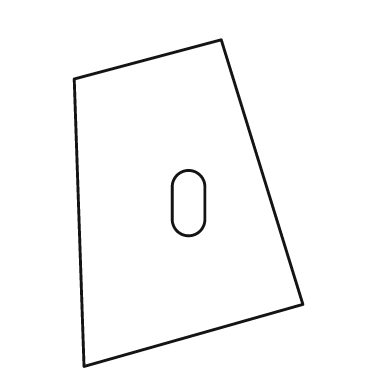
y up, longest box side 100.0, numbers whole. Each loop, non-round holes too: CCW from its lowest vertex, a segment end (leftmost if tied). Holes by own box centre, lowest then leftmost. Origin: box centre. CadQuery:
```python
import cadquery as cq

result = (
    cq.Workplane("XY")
    .moveTo(-32.0, -50.0)
    .lineTo(35.0, -31.0)
    .lineTo(10.0, 50.0)
    .lineTo(-35.0, 38.0)
    .close()
    .moveTo(-5.0, -5.0)
    .threePointArc((0.0, -10.0), (5.0, -5.0))
    .lineTo(5.0, 5.0)
    .threePointArc((0.0, 10.0), (-5.0, 5.0))
    .close()
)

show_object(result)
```